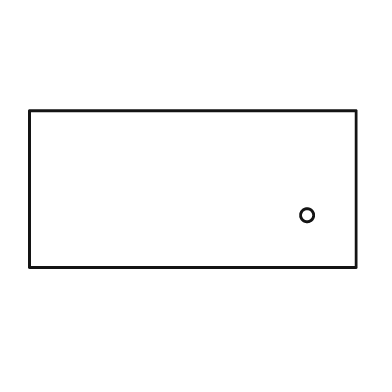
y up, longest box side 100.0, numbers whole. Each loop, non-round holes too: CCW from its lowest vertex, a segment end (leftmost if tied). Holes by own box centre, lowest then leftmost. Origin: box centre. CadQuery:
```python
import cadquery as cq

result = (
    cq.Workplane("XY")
    .moveTo(-50.0, -24.0)
    .lineTo(50.0, -24.0)
    .lineTo(50.0, 24.0)
    .lineTo(-50.0, 24.0)
    .close()
    .moveTo(35.0, -8.0)
    .circle(2.0)
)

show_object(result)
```